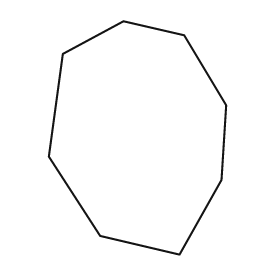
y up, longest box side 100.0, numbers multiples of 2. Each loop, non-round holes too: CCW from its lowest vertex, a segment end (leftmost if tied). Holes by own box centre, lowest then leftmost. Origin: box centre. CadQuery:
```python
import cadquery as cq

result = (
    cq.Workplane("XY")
    .moveTo(18.0, -50.0)
    .lineTo(36.0, -18.0)
    .lineTo(38.0, 14.0)
    .lineTo(20.0, 44.0)
    .lineTo(-6.0, 50.0)
    .lineTo(-32.0, 36.0)
    .lineTo(-38.0, -8.0)
    .lineTo(-16.0, -42.0)
    .close()
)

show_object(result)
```